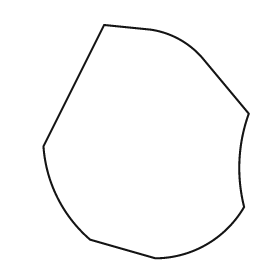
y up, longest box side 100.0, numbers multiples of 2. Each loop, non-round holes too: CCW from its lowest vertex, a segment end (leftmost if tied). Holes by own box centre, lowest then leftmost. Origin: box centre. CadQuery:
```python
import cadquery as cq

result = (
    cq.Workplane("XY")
    .moveTo(4.0, -50.0)
    .threePointArc((26.0, -44.0), (42.0, -28.0))
    .threePointArc((40.0, -8.0), (44.0, 12.0))
    .lineTo(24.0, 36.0)
    .threePointArc((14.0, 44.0), (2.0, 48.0))
    .lineTo(-18.0, 50.0)
    .lineTo(-44.0, -2.0)
    .threePointArc((-38.0, -24.0), (-24.0, -42.0))
    .close()
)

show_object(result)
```